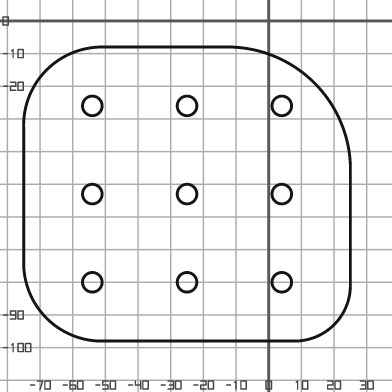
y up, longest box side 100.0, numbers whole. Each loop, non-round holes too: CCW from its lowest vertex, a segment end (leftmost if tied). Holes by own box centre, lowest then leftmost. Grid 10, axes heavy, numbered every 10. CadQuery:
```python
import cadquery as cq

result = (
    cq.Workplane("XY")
    .moveTo(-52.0, -98.0)
    .lineTo(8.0, -98.0)
    .threePointArc((20.0, -93.0), (25.0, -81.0))
    .lineTo(25.0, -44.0)
    .threePointArc((14.0, -19.0), (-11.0, -8.0))
    .lineTo(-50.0, -8.0)
    .threePointArc((-68.0, -15.0), (-75.0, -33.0))
    .lineTo(-75.0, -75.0)
    .threePointArc((-68.0, -91.0), (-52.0, -98.0))
    .close()
    .moveTo(-54.0, -80.0)
    .circle(3.0)
    .moveTo(-25.0, -80.0)
    .circle(3.0)
    .moveTo(4.0, -80.0)
    .circle(3.0)
    .moveTo(-54.0, -53.0)
    .circle(3.0)
    .moveTo(-25.0, -53.0)
    .circle(3.0)
    .moveTo(4.0, -53.0)
    .circle(3.0)
    .moveTo(-54.0, -26.0)
    .circle(3.0)
    .moveTo(-25.0, -26.0)
    .circle(3.0)
    .moveTo(4.0, -26.0)
    .circle(3.0)
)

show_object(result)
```